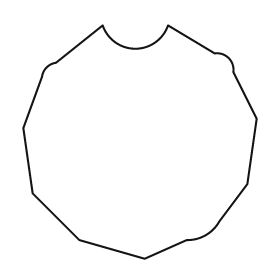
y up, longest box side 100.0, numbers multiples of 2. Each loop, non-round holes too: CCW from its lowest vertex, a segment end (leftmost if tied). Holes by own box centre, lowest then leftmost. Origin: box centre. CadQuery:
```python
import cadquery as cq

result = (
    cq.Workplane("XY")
    .moveTo(2.0, -50.0)
    .lineTo(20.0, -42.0)
    .threePointArc((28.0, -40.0), (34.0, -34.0))
    .lineTo(46.0, -18.0)
    .lineTo(50.0, 10.0)
    .lineTo(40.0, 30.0)
    .threePointArc((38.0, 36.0), (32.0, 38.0))
    .lineTo(12.0, 50.0)
    .threePointArc((-2.0, 40.0), (-16.0, 50.0))
    .lineTo(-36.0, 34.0)
    .threePointArc((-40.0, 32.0), (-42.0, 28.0))
    .lineTo(-50.0, 6.0)
    .lineTo(-46.0, -22.0)
    .lineTo(-26.0, -42.0)
    .close()
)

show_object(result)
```